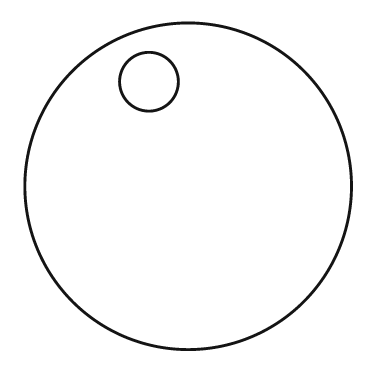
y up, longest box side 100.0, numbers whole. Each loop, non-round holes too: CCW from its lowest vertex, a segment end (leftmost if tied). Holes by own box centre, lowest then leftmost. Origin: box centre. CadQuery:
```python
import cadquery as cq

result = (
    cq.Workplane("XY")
    .moveTo(0.0, 0.0)
    .circle(50.0)
    .moveTo(-12.0, 32.0)
    .circle(9.0)
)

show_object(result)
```